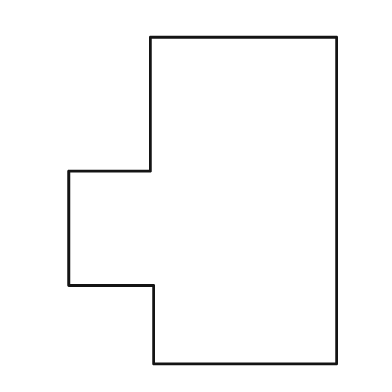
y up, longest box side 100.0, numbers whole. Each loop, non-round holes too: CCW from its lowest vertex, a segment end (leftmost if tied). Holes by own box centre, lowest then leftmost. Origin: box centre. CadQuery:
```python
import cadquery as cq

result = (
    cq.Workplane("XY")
    .moveTo(-15.0, -50.0)
    .lineTo(41.0, -50.0)
    .lineTo(41.0, 50.0)
    .lineTo(-16.0, 50.0)
    .lineTo(-16.0, 9.0)
    .lineTo(-41.0, 9.0)
    .lineTo(-41.0, -26.0)
    .lineTo(-15.0, -26.0)
    .close()
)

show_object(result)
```